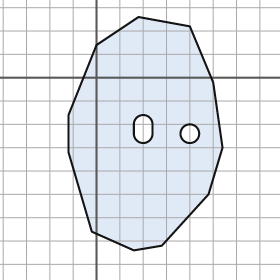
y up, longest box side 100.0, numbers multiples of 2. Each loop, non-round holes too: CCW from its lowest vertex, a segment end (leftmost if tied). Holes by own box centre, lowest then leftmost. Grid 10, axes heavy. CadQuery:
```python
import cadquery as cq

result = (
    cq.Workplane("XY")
    .moveTo(16.0, -74.0)
    .lineTo(28.0, -72.0)
    .lineTo(48.0, -50.0)
    .lineTo(54.0, -30.0)
    .lineTo(50.0, -2.0)
    .lineTo(40.0, 22.0)
    .lineTo(18.0, 26.0)
    .lineTo(0.0, 14.0)
    .lineTo(-12.0, -16.0)
    .lineTo(-12.0, -32.0)
    .lineTo(-2.0, -66.0)
    .close()
    .moveTo(40.0, -24.0)
    .circle(4.0)
    .moveTo(16.0, -24.0)
    .threePointArc((20.0, -28.0), (24.0, -24.0))
    .lineTo(24.0, -20.0)
    .threePointArc((20.0, -16.0), (16.0, -20.0))
    .close()
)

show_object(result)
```